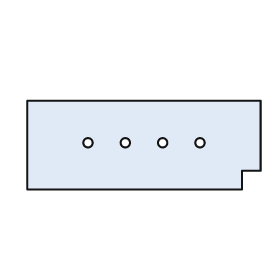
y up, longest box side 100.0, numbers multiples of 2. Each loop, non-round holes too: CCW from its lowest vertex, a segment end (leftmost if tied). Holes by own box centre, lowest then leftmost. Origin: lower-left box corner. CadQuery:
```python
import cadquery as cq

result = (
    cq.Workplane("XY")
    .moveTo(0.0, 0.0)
    .lineTo(92.0, 0.0)
    .lineTo(92.0, 8.0)
    .lineTo(100.0, 8.0)
    .lineTo(100.0, 38.0)
    .lineTo(0.0, 38.0)
    .close()
    .moveTo(26.0, 20.0)
    .circle(2.0)
    .moveTo(42.0, 20.0)
    .circle(2.0)
    .moveTo(58.0, 20.0)
    .circle(2.0)
    .moveTo(74.0, 20.0)
    .circle(2.0)
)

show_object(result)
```